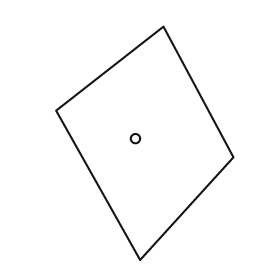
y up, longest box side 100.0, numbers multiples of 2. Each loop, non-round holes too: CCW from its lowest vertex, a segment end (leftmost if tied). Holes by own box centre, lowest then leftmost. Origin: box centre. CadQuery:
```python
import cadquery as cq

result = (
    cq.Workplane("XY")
    .moveTo(-2.0, -50.0)
    .lineTo(38.0, -6.0)
    .lineTo(8.0, 50.0)
    .lineTo(-38.0, 14.0)
    .close()
    .moveTo(-4.0, 2.0)
    .circle(2.0)
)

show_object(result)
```